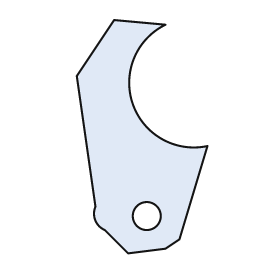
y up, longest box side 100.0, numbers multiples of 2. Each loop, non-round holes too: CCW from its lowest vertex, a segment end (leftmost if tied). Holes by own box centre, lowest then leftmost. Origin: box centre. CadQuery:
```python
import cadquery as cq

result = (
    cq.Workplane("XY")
    .moveTo(-6.0, -50.0)
    .lineTo(10.0, -48.0)
    .lineTo(16.0, -44.0)
    .lineTo(28.0, -4.0)
    .threePointArc((-4.0, 14.0), (10.0, 48.0))
    .lineTo(-12.0, 50.0)
    .lineTo(-28.0, 26.0)
    .lineTo(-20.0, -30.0)
    .threePointArc((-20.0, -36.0), (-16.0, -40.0))
    .close()
    .moveTo(2.0, -34.0)
    .circle(6.0)
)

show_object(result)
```